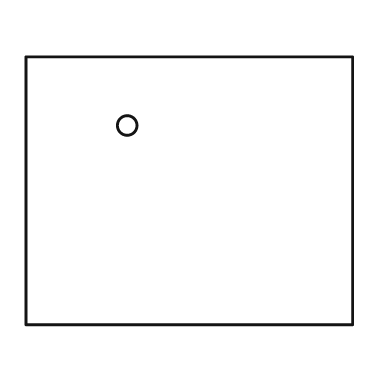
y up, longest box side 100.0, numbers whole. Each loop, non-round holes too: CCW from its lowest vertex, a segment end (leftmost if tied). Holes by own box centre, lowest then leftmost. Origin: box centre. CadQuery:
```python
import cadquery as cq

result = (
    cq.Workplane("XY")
    .moveTo(-50.0, -41.0)
    .lineTo(50.0, -41.0)
    .lineTo(50.0, 41.0)
    .lineTo(-50.0, 41.0)
    .close()
    .moveTo(-19.0, 20.0)
    .circle(3.0)
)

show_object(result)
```